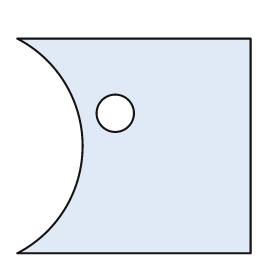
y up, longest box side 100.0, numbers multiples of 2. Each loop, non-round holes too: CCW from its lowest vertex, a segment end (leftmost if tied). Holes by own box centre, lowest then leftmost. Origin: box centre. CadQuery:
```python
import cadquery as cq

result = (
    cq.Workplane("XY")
    .moveTo(-50.0, -46.0)
    .lineTo(50.0, -46.0)
    .lineTo(50.0, 46.0)
    .lineTo(-50.0, 46.0)
    .threePointArc((-22.0, 0.0), (-50.0, -46.0))
    .close()
    .moveTo(-8.0, 14.0)
    .circle(8.0)
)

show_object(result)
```